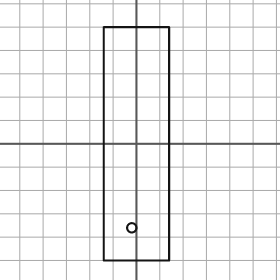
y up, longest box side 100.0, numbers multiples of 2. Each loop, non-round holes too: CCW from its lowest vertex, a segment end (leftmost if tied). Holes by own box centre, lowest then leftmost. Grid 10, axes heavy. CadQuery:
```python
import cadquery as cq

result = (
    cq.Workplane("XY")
    .moveTo(-14.0, -50.0)
    .lineTo(14.0, -50.0)
    .lineTo(14.0, 50.0)
    .lineTo(-14.0, 50.0)
    .close()
    .moveTo(-2.0, -36.0)
    .circle(2.0)
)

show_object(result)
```